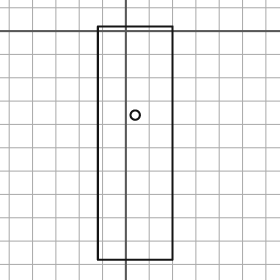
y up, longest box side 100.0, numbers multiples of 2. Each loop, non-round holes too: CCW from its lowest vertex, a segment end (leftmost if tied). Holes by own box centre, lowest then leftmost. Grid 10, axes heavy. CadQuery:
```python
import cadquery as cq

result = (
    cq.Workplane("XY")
    .moveTo(-12.0, -98.0)
    .lineTo(20.0, -98.0)
    .lineTo(20.0, 2.0)
    .lineTo(-12.0, 2.0)
    .close()
    .moveTo(4.0, -36.0)
    .circle(2.0)
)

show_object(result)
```